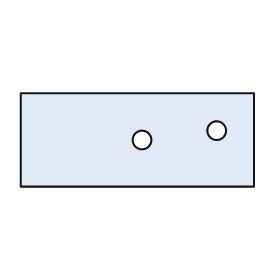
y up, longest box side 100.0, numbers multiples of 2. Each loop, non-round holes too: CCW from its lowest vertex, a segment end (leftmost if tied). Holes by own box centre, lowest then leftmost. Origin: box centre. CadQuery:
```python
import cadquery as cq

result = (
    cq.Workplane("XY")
    .moveTo(-50.0, -20.0)
    .lineTo(50.0, -20.0)
    .lineTo(50.0, 20.0)
    .lineTo(-50.0, 20.0)
    .close()
    .moveTo(2.0, 0.0)
    .circle(4.0)
    .moveTo(34.0, 4.0)
    .circle(4.0)
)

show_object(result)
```